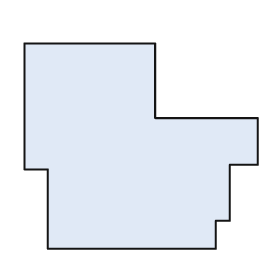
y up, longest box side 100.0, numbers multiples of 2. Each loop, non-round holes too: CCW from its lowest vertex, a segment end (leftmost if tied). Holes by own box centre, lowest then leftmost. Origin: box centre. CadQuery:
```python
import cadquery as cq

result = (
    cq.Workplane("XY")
    .moveTo(-40.0, -44.0)
    .lineTo(32.0, -44.0)
    .lineTo(32.0, -32.0)
    .lineTo(38.0, -32.0)
    .lineTo(38.0, -8.0)
    .lineTo(50.0, -8.0)
    .lineTo(50.0, 12.0)
    .lineTo(6.0, 12.0)
    .lineTo(6.0, 44.0)
    .lineTo(-50.0, 44.0)
    .lineTo(-50.0, -10.0)
    .lineTo(-40.0, -10.0)
    .close()
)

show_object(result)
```